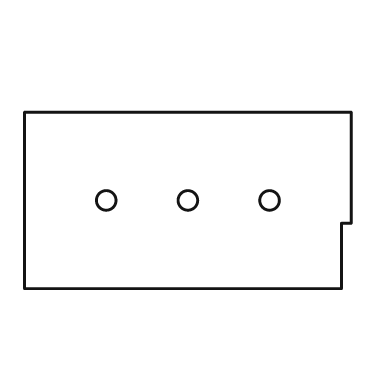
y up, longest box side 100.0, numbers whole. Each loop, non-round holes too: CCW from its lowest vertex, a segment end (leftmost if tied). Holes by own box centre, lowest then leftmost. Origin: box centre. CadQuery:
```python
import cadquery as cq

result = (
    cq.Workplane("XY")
    .moveTo(-50.0, -27.0)
    .lineTo(47.0, -27.0)
    .lineTo(47.0, -7.0)
    .lineTo(50.0, -7.0)
    .lineTo(50.0, 27.0)
    .lineTo(-50.0, 27.0)
    .close()
    .moveTo(-25.0, 0.0)
    .circle(3.0)
    .moveTo(0.0, 0.0)
    .circle(3.0)
    .moveTo(25.0, 0.0)
    .circle(3.0)
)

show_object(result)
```